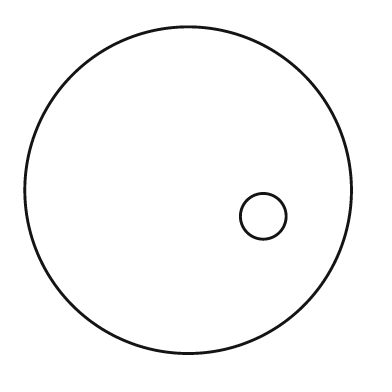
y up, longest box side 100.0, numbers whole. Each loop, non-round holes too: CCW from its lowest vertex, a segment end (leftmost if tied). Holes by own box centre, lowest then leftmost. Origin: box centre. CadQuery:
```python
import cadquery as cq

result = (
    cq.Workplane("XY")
    .moveTo(0.0, 0.0)
    .circle(50.0)
    .moveTo(23.0, -8.0)
    .circle(7.0)
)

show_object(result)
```